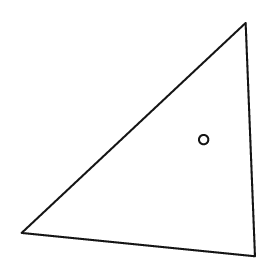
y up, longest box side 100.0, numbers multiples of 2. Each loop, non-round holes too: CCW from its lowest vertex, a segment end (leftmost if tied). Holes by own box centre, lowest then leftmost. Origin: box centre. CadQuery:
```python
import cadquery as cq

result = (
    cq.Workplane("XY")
    .moveTo(50.0, -50.0)
    .lineTo(46.0, 50.0)
    .lineTo(-50.0, -40.0)
    .close()
    .moveTo(28.0, 0.0)
    .circle(2.0)
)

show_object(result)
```